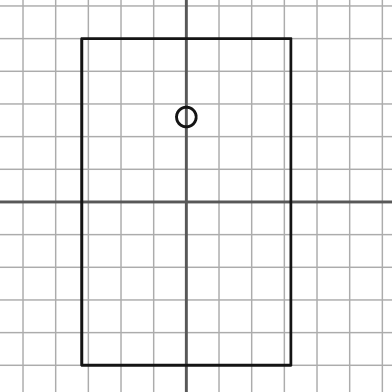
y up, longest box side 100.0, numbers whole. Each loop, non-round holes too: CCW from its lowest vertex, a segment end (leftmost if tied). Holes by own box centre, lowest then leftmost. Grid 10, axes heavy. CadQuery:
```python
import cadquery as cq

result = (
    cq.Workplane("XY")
    .moveTo(-32.0, -50.0)
    .lineTo(32.0, -50.0)
    .lineTo(32.0, 50.0)
    .lineTo(-32.0, 50.0)
    .close()
    .moveTo(0.0, 26.0)
    .circle(3.0)
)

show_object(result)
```